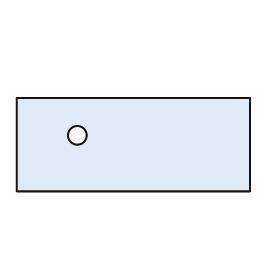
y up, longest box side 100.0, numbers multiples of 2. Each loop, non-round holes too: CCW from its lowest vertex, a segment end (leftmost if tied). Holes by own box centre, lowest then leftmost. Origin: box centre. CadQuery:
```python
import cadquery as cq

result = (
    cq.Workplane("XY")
    .moveTo(-50.0, -20.0)
    .lineTo(50.0, -20.0)
    .lineTo(50.0, 20.0)
    .lineTo(-50.0, 20.0)
    .close()
    .moveTo(-24.0, 4.0)
    .circle(4.0)
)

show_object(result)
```